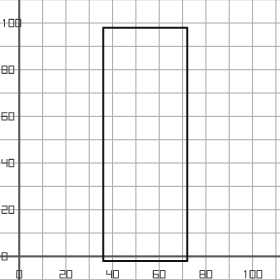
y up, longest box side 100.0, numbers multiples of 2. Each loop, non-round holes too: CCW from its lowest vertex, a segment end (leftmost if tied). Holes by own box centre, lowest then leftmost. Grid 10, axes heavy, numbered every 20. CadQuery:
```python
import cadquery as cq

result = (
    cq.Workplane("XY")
    .moveTo(36.0, -2.0)
    .lineTo(72.0, -2.0)
    .lineTo(72.0, 98.0)
    .lineTo(36.0, 98.0)
    .close()
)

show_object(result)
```